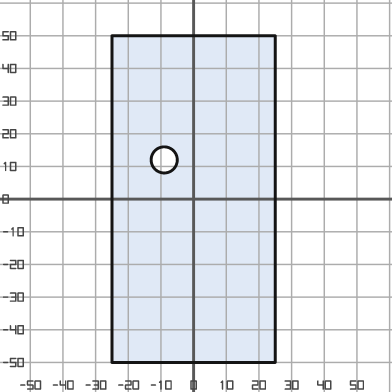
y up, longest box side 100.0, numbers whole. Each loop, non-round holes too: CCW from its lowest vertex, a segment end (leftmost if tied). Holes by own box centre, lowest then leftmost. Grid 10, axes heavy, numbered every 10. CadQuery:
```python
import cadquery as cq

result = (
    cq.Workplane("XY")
    .moveTo(-25.0, -50.0)
    .lineTo(25.0, -50.0)
    .lineTo(25.0, 50.0)
    .lineTo(-25.0, 50.0)
    .close()
    .moveTo(-9.0, 12.0)
    .circle(4.0)
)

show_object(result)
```